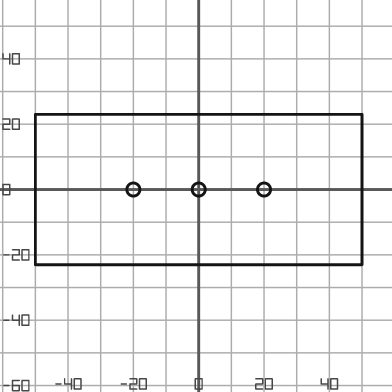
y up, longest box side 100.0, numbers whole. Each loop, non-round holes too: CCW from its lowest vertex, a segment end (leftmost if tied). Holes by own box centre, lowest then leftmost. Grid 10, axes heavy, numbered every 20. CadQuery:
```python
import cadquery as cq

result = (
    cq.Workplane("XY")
    .moveTo(-50.0, -23.0)
    .lineTo(50.0, -23.0)
    .lineTo(50.0, 23.0)
    .lineTo(-50.0, 23.0)
    .close()
    .moveTo(-20.0, 0.0)
    .circle(2.0)
    .moveTo(0.0, 0.0)
    .circle(2.0)
    .moveTo(20.0, 0.0)
    .circle(2.0)
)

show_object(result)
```